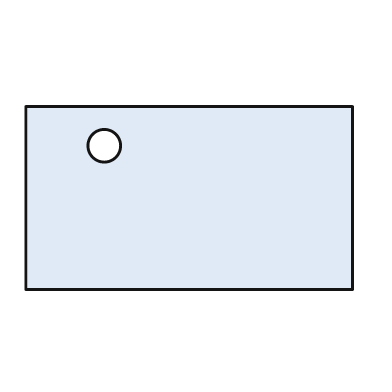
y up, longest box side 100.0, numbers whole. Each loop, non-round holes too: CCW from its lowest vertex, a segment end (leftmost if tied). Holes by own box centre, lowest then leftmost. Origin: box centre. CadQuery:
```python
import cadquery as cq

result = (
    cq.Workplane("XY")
    .moveTo(-50.0, -28.0)
    .lineTo(50.0, -28.0)
    .lineTo(50.0, 28.0)
    .lineTo(-50.0, 28.0)
    .close()
    .moveTo(-26.0, 16.0)
    .circle(5.0)
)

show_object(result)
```